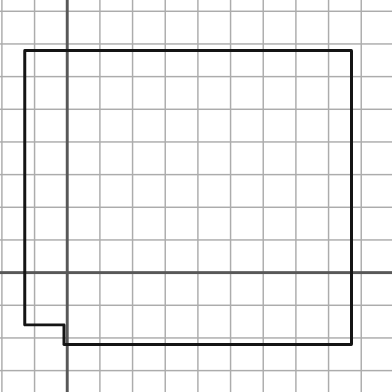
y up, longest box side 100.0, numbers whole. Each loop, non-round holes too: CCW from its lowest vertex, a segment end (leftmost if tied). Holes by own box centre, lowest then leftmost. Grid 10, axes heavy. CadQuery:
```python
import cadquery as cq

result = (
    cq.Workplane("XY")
    .moveTo(-1.0, -22.0)
    .lineTo(87.0, -22.0)
    .lineTo(87.0, 68.0)
    .lineTo(-13.0, 68.0)
    .lineTo(-13.0, -16.0)
    .lineTo(-1.0, -16.0)
    .close()
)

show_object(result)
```